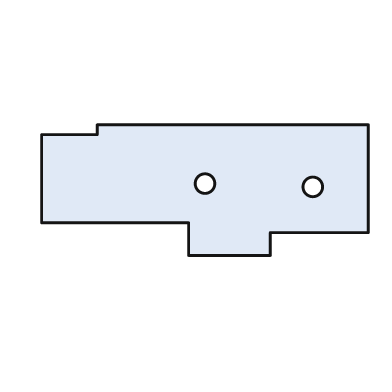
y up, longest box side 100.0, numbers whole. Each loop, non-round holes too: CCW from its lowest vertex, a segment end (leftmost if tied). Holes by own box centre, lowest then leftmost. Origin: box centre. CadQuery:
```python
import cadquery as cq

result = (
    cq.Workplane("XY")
    .moveTo(-5.0, -20.0)
    .lineTo(20.0, -20.0)
    .lineTo(20.0, -13.0)
    .lineTo(50.0, -13.0)
    .lineTo(50.0, 20.0)
    .lineTo(-33.0, 20.0)
    .lineTo(-33.0, 17.0)
    .lineTo(-50.0, 17.0)
    .lineTo(-50.0, -10.0)
    .lineTo(-5.0, -10.0)
    .close()
    .moveTo(33.0, 1.0)
    .circle(3.0)
    .moveTo(0.0, 2.0)
    .circle(3.0)
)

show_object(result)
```